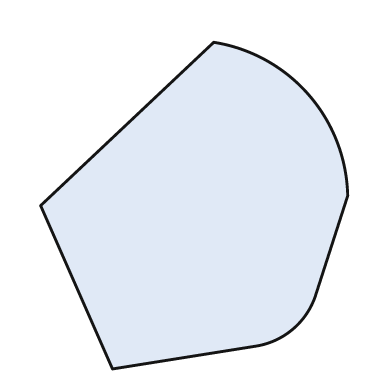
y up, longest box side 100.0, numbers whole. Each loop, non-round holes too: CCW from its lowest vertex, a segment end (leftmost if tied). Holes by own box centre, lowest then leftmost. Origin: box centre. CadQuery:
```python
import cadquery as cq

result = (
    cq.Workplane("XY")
    .moveTo(-25.0, -50.0)
    .lineTo(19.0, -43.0)
    .threePointArc((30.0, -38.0), (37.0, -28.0))
    .lineTo(47.0, 3.0)
    .threePointArc((35.0, 34.0), (6.0, 50.0))
    .lineTo(-47.0, 0.0)
    .close()
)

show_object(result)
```